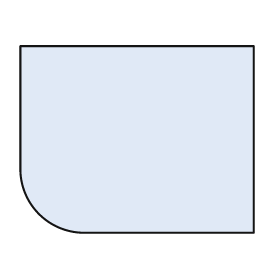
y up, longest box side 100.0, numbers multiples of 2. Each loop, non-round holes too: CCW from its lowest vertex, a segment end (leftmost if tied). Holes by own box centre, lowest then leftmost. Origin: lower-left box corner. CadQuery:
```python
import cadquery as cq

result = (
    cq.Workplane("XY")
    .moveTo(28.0, 0.0)
    .lineTo(100.0, 0.0)
    .lineTo(100.0, 80.0)
    .lineTo(0.0, 80.0)
    .lineTo(0.0, 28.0)
    .threePointArc((8.0, 8.0), (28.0, 0.0))
    .close()
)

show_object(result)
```